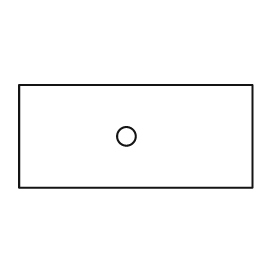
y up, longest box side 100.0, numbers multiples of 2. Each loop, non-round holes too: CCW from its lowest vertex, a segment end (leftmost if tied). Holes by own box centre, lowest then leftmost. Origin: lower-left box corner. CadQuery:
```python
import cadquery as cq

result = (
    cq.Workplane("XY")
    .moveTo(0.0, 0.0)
    .lineTo(100.0, 0.0)
    .lineTo(100.0, 44.0)
    .lineTo(0.0, 44.0)
    .close()
    .moveTo(46.0, 22.0)
    .circle(4.0)
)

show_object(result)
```